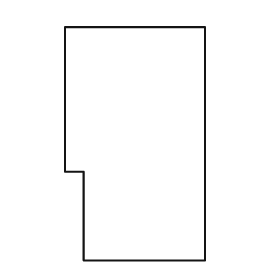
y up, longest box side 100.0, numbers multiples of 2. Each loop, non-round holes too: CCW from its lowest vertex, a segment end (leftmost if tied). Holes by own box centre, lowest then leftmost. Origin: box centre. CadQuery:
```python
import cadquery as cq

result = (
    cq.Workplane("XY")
    .moveTo(-22.0, -50.0)
    .lineTo(30.0, -50.0)
    .lineTo(30.0, 50.0)
    .lineTo(-30.0, 50.0)
    .lineTo(-30.0, -12.0)
    .lineTo(-22.0, -12.0)
    .close()
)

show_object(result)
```